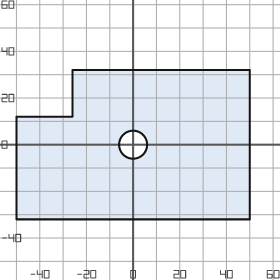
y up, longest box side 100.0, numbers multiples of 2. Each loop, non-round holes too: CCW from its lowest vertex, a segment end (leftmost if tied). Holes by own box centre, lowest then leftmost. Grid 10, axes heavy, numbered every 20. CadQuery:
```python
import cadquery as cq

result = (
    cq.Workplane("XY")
    .moveTo(-50.0, -32.0)
    .lineTo(50.0, -32.0)
    .lineTo(50.0, 32.0)
    .lineTo(-26.0, 32.0)
    .lineTo(-26.0, 12.0)
    .lineTo(-50.0, 12.0)
    .close()
    .moveTo(0.0, 0.0)
    .circle(6.0)
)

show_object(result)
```